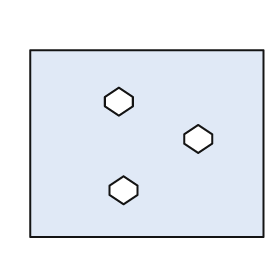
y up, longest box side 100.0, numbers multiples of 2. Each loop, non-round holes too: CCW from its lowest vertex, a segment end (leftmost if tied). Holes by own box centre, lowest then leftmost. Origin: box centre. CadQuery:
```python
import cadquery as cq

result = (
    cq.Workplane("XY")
    .moveTo(-50.0, -40.0)
    .lineTo(50.0, -40.0)
    .lineTo(50.0, 40.0)
    .lineTo(-50.0, 40.0)
    .close()
    .moveTo(-10.0, -26.0)
    .lineTo(-4.0, -22.0)
    .lineTo(-4.0, -18.0)
    .lineTo(-10.0, -14.0)
    .lineTo(-16.0, -18.0)
    .lineTo(-16.0, -22.0)
    .close()
    .moveTo(22.0, -4.0)
    .lineTo(28.0, 0.0)
    .lineTo(28.0, 4.0)
    .lineTo(22.0, 8.0)
    .lineTo(16.0, 4.0)
    .lineTo(16.0, 0.0)
    .close()
    .moveTo(-12.0, 12.0)
    .lineTo(-6.0, 16.0)
    .lineTo(-6.0, 20.0)
    .lineTo(-12.0, 24.0)
    .lineTo(-18.0, 20.0)
    .lineTo(-18.0, 16.0)
    .close()
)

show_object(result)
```